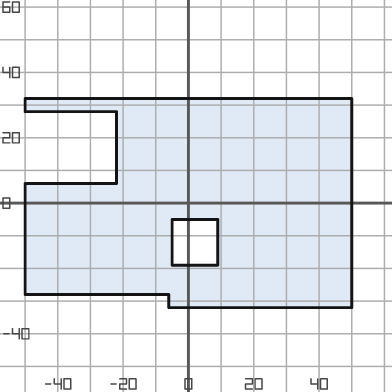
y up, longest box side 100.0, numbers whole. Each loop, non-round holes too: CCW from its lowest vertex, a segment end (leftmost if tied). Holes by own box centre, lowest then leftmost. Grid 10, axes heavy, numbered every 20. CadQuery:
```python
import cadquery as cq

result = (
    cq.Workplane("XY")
    .moveTo(-6.0, -32.0)
    .lineTo(50.0, -32.0)
    .lineTo(50.0, 32.0)
    .lineTo(-50.0, 32.0)
    .lineTo(-50.0, 28.0)
    .lineTo(-22.0, 28.0)
    .lineTo(-22.0, 6.0)
    .lineTo(-50.0, 6.0)
    .lineTo(-50.0, -28.0)
    .lineTo(-6.0, -28.0)
    .close()
    .moveTo(-5.0, -19.0)
    .lineTo(9.0, -19.0)
    .lineTo(9.0, -5.0)
    .lineTo(-5.0, -5.0)
    .close()
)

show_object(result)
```